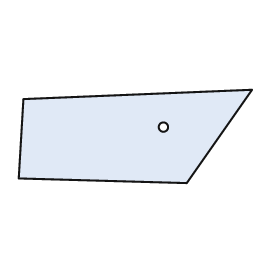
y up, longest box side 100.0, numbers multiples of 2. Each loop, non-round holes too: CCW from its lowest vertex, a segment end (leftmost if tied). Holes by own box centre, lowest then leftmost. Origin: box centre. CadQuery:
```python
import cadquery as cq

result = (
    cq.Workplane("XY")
    .moveTo(22.0, -20.0)
    .lineTo(50.0, 20.0)
    .lineTo(-48.0, 16.0)
    .lineTo(-50.0, -18.0)
    .close()
    .moveTo(12.0, 4.0)
    .circle(2.0)
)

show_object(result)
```